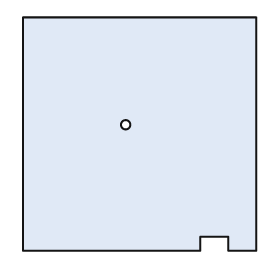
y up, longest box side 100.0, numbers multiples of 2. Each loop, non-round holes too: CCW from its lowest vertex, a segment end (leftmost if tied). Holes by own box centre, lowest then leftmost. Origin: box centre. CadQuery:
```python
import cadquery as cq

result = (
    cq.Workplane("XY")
    .moveTo(-50.0, -50.0)
    .lineTo(26.0, -50.0)
    .lineTo(26.0, -44.0)
    .lineTo(38.0, -44.0)
    .lineTo(38.0, -50.0)
    .lineTo(50.0, -50.0)
    .lineTo(50.0, 50.0)
    .lineTo(-50.0, 50.0)
    .close()
    .moveTo(-6.0, 4.0)
    .circle(2.0)
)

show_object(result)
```